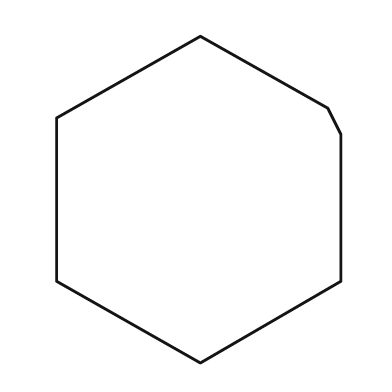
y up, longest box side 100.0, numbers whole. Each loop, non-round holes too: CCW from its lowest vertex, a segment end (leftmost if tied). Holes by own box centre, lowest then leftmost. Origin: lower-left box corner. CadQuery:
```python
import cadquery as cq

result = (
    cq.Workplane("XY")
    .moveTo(44.0, 0.0)
    .lineTo(87.0, 25.0)
    .lineTo(87.0, 70.0)
    .lineTo(83.0, 78.0)
    .lineTo(44.0, 100.0)
    .lineTo(0.0, 75.0)
    .lineTo(0.0, 25.0)
    .close()
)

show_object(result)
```